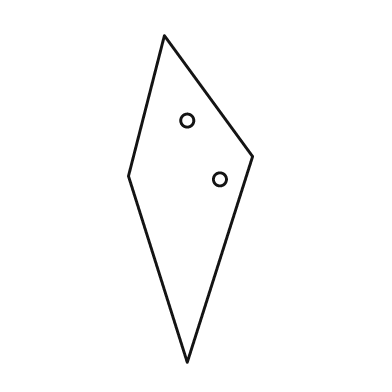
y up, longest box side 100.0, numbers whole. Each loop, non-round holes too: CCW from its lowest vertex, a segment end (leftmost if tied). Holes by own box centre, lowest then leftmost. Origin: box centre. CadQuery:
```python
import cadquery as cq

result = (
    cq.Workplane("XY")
    .moveTo(-1.0, -50.0)
    .lineTo(19.0, 13.0)
    .lineTo(-8.0, 50.0)
    .lineTo(-19.0, 7.0)
    .close()
    .moveTo(9.0, 6.0)
    .circle(2.0)
    .moveTo(-1.0, 24.0)
    .circle(2.0)
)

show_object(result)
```